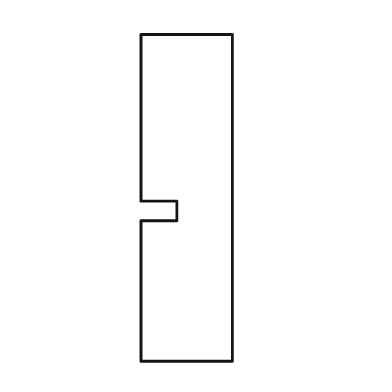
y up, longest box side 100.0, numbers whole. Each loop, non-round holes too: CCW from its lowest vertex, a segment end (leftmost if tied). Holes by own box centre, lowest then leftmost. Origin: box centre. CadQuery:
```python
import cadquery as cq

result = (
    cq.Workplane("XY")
    .moveTo(-14.0, -50.0)
    .lineTo(14.0, -50.0)
    .lineTo(14.0, 50.0)
    .lineTo(-14.0, 50.0)
    .lineTo(-14.0, -1.0)
    .lineTo(-3.0, -1.0)
    .lineTo(-3.0, -7.0)
    .lineTo(-14.0, -7.0)
    .close()
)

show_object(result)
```